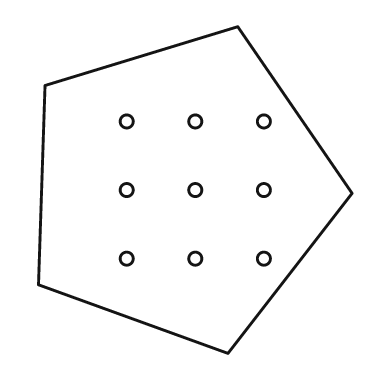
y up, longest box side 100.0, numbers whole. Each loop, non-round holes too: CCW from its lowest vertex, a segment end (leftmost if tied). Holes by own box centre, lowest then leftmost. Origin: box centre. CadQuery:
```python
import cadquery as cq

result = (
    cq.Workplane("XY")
    .moveTo(10.0, -50.0)
    .lineTo(48.0, -1.0)
    .lineTo(13.0, 50.0)
    .lineTo(-46.0, 32.0)
    .lineTo(-48.0, -29.0)
    .close()
    .moveTo(-21.0, -21.0)
    .circle(2.0)
    .moveTo(0.0, -21.0)
    .circle(2.0)
    .moveTo(21.0, -21.0)
    .circle(2.0)
    .moveTo(-21.0, 0.0)
    .circle(2.0)
    .moveTo(0.0, 0.0)
    .circle(2.0)
    .moveTo(21.0, 0.0)
    .circle(2.0)
    .moveTo(-21.0, 21.0)
    .circle(2.0)
    .moveTo(0.0, 21.0)
    .circle(2.0)
    .moveTo(21.0, 21.0)
    .circle(2.0)
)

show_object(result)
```